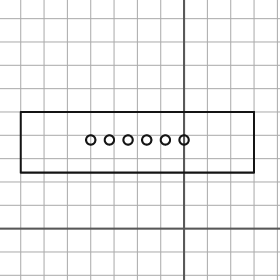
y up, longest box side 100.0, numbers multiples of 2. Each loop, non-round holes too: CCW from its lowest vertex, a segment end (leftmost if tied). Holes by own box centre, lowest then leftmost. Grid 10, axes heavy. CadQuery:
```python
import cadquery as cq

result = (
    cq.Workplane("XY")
    .moveTo(-70.0, 24.0)
    .lineTo(30.0, 24.0)
    .lineTo(30.0, 50.0)
    .lineTo(-70.0, 50.0)
    .close()
    .moveTo(-40.0, 38.0)
    .circle(2.0)
    .moveTo(-32.0, 38.0)
    .circle(2.0)
    .moveTo(-24.0, 38.0)
    .circle(2.0)
    .moveTo(-16.0, 38.0)
    .circle(2.0)
    .moveTo(-8.0, 38.0)
    .circle(2.0)
    .moveTo(0.0, 38.0)
    .circle(2.0)
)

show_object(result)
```